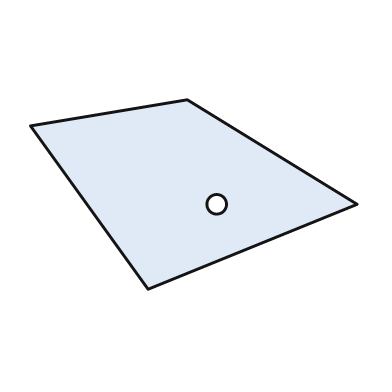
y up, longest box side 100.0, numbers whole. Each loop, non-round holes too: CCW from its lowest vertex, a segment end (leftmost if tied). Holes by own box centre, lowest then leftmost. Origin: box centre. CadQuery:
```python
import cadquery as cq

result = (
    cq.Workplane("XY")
    .moveTo(-14.0, -29.0)
    .lineTo(50.0, -3.0)
    .lineTo(-2.0, 29.0)
    .lineTo(-50.0, 21.0)
    .close()
    .moveTo(7.0, -3.0)
    .circle(3.0)
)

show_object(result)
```